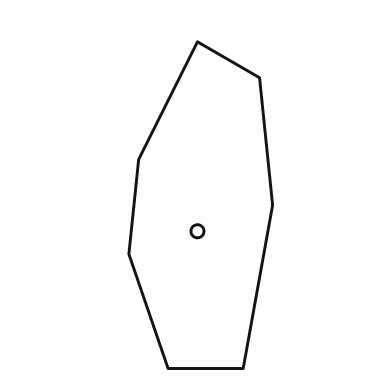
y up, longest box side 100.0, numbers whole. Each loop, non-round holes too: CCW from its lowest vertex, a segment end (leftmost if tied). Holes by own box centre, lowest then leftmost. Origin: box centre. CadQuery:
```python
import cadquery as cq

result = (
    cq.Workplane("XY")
    .moveTo(-10.0, -50.0)
    .lineTo(13.0, -50.0)
    .lineTo(22.0, 0.0)
    .lineTo(18.0, 39.0)
    .lineTo(-1.0, 50.0)
    .lineTo(-19.0, 14.0)
    .lineTo(-22.0, -15.0)
    .close()
    .moveTo(-1.0, -8.0)
    .circle(2.0)
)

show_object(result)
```